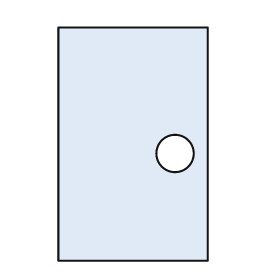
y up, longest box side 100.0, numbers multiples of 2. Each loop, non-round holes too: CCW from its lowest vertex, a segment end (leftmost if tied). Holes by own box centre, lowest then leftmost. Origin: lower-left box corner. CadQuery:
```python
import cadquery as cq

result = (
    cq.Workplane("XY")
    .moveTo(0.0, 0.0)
    .lineTo(64.0, 0.0)
    .lineTo(64.0, 100.0)
    .lineTo(0.0, 100.0)
    .close()
    .moveTo(50.0, 46.0)
    .circle(8.0)
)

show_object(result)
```